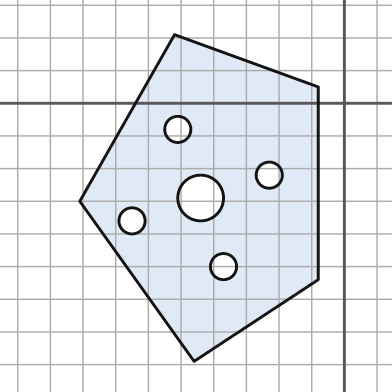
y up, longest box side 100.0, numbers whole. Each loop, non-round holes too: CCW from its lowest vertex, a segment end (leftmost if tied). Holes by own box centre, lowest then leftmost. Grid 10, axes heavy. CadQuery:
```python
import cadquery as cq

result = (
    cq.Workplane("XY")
    .moveTo(-46.0, -79.0)
    .lineTo(-8.0, -54.0)
    .lineTo(-8.0, 5.0)
    .lineTo(-52.0, 21.0)
    .lineTo(-81.0, -30.0)
    .close()
    .moveTo(-37.0, -50.0)
    .circle(4.0)
    .moveTo(-65.0, -36.0)
    .circle(4.0)
    .moveTo(-44.0, -29.0)
    .circle(7.0)
    .moveTo(-23.0, -22.0)
    .circle(4.0)
    .moveTo(-51.0, -8.0)
    .circle(4.0)
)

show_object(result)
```